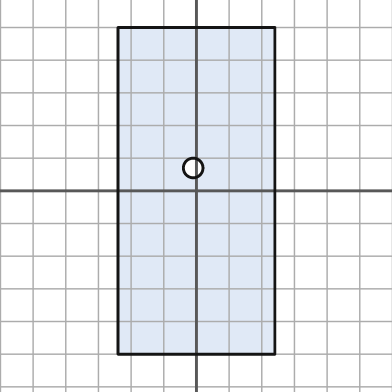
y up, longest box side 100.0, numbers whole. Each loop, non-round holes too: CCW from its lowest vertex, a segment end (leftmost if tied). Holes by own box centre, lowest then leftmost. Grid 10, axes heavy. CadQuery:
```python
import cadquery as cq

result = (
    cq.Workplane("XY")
    .moveTo(-24.0, -50.0)
    .lineTo(24.0, -50.0)
    .lineTo(24.0, 50.0)
    .lineTo(-24.0, 50.0)
    .close()
    .moveTo(-1.0, 7.0)
    .circle(3.0)
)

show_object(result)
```